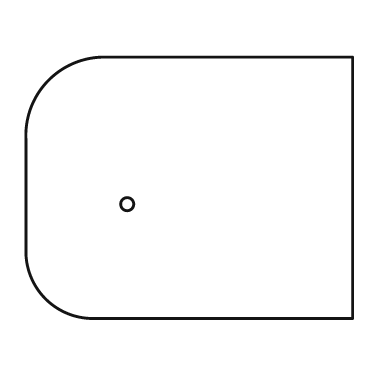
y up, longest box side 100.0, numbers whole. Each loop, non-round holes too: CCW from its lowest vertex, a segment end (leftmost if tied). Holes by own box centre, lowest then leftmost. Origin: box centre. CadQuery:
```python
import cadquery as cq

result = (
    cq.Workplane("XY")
    .moveTo(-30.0, -40.0)
    .lineTo(50.0, -40.0)
    .lineTo(50.0, 40.0)
    .lineTo(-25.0, 40.0)
    .threePointArc((-43.0, 33.0), (-50.0, 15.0))
    .lineTo(-50.0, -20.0)
    .threePointArc((-44.0, -34.0), (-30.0, -40.0))
    .close()
    .moveTo(-19.0, -5.0)
    .circle(2.0)
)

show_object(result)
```